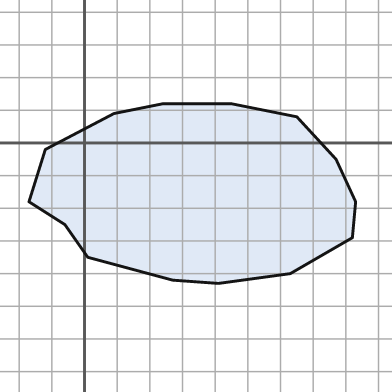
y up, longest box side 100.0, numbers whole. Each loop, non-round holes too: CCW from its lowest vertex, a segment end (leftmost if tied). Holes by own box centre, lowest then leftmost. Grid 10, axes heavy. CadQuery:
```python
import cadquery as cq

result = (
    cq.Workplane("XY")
    .moveTo(41.0, -43.0)
    .lineTo(63.0, -40.0)
    .lineTo(82.0, -29.0)
    .lineTo(83.0, -18.0)
    .lineTo(77.0, -5.0)
    .lineTo(65.0, 8.0)
    .lineTo(45.0, 12.0)
    .lineTo(24.0, 12.0)
    .lineTo(9.0, 9.0)
    .lineTo(-12.0, -2.0)
    .lineTo(-17.0, -18.0)
    .lineTo(-6.0, -25.0)
    .lineTo(1.0, -35.0)
    .lineTo(27.0, -42.0)
    .close()
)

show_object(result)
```